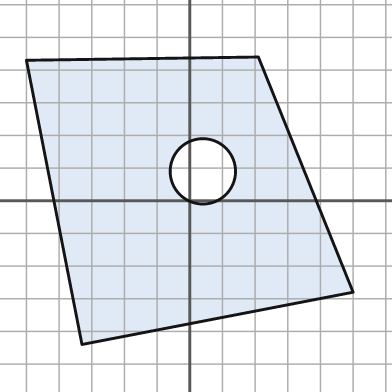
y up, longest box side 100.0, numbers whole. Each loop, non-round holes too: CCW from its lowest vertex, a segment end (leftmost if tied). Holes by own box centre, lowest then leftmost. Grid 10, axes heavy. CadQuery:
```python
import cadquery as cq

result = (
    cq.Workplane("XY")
    .moveTo(-33.0, -44.0)
    .lineTo(50.0, -28.0)
    .lineTo(21.0, 44.0)
    .lineTo(-50.0, 43.0)
    .close()
    .moveTo(4.0, 9.0)
    .circle(10.0)
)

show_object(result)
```